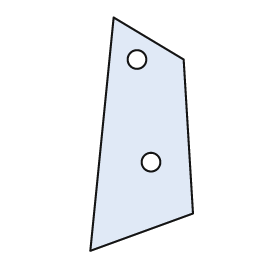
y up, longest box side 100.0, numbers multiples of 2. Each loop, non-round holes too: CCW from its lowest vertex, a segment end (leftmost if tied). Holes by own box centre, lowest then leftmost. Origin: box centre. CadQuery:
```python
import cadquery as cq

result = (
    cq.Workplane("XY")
    .moveTo(-22.0, -50.0)
    .lineTo(22.0, -34.0)
    .lineTo(18.0, 32.0)
    .lineTo(-12.0, 50.0)
    .close()
    .moveTo(4.0, -12.0)
    .circle(4.0)
    .moveTo(-2.0, 32.0)
    .circle(4.0)
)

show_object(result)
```